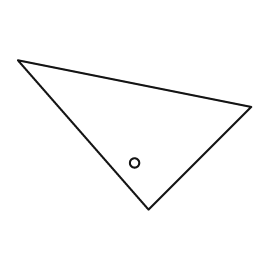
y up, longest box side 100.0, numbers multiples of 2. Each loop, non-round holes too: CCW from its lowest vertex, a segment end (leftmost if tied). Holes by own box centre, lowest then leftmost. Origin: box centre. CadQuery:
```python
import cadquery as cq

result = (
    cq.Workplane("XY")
    .moveTo(6.0, -32.0)
    .lineTo(50.0, 12.0)
    .lineTo(-50.0, 32.0)
    .close()
    .moveTo(0.0, -12.0)
    .circle(2.0)
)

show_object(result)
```